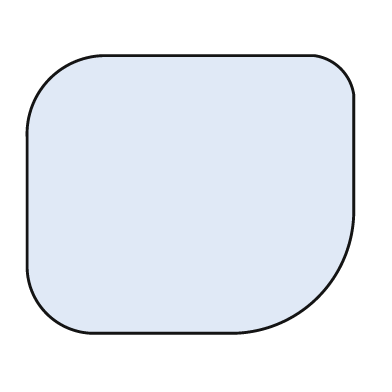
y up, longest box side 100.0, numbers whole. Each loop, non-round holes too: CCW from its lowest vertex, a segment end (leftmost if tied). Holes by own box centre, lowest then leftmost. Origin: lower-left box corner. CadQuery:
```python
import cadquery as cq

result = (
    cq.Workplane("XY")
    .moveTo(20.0, 0.0)
    .lineTo(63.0, 0.0)
    .threePointArc((89.0, 11.0), (100.0, 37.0))
    .lineTo(100.0, 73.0)
    .threePointArc((96.0, 81.0), (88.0, 85.0))
    .lineTo(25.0, 85.0)
    .threePointArc((7.0, 78.0), (0.0, 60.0))
    .lineTo(0.0, 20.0)
    .threePointArc((6.0, 6.0), (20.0, 0.0))
    .close()
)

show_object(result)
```